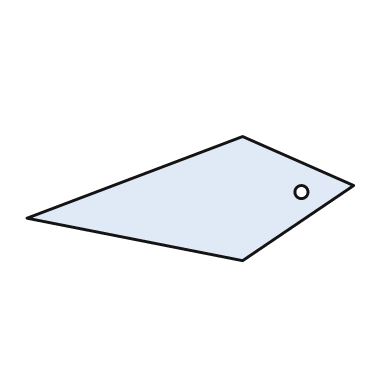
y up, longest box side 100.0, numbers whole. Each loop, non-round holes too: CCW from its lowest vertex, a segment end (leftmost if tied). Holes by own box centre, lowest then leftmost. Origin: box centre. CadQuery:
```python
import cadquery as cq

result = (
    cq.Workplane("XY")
    .moveTo(16.0, -19.0)
    .lineTo(50.0, 4.0)
    .lineTo(16.0, 19.0)
    .lineTo(-50.0, -6.0)
    .close()
    .moveTo(34.0, 2.0)
    .circle(2.0)
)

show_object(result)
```